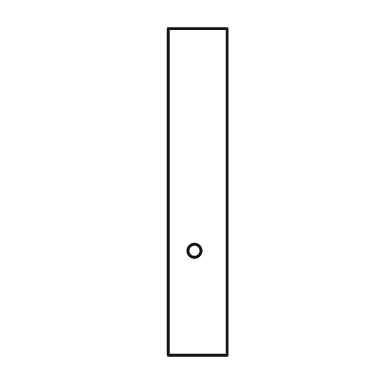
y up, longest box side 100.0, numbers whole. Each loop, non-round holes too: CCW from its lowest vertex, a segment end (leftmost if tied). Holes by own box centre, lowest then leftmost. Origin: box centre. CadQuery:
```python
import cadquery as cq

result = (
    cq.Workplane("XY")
    .moveTo(-9.0, -50.0)
    .lineTo(9.0, -50.0)
    .lineTo(9.0, 50.0)
    .lineTo(-9.0, 50.0)
    .close()
    .moveTo(-1.0, -18.0)
    .circle(2.0)
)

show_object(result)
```